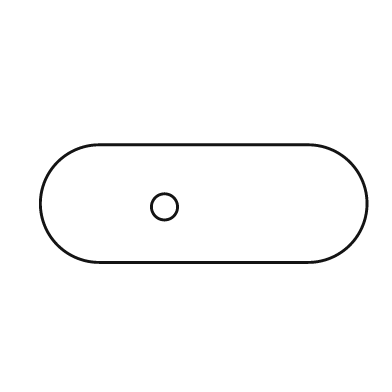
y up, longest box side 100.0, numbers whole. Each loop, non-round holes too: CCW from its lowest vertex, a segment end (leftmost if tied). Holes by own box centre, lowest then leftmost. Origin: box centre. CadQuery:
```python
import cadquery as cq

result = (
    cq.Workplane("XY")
    .moveTo(-32.0, -18.0)
    .lineTo(32.0, -18.0)
    .threePointArc((50.0, 0.0), (32.0, 18.0))
    .lineTo(-32.0, 18.0)
    .threePointArc((-50.0, 0.0), (-32.0, -18.0))
    .close()
    .moveTo(-12.0, -1.0)
    .circle(4.0)
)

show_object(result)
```